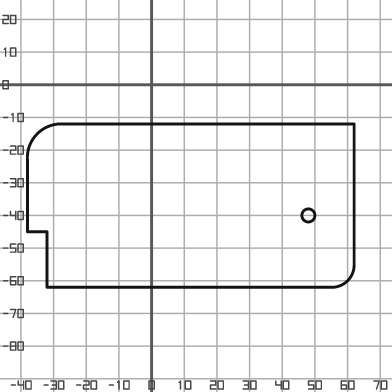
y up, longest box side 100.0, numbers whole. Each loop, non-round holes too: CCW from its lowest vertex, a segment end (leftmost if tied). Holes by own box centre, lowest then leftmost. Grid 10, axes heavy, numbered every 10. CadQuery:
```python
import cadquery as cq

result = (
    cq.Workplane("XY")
    .moveTo(-32.0, -62.0)
    .lineTo(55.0, -62.0)
    .threePointArc((60.0, -60.0), (62.0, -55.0))
    .lineTo(62.0, -12.0)
    .lineTo(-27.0, -12.0)
    .threePointArc((-35.0, -15.0), (-38.0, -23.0))
    .lineTo(-38.0, -45.0)
    .lineTo(-32.0, -45.0)
    .close()
    .moveTo(48.0, -40.0)
    .circle(2.0)
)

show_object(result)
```